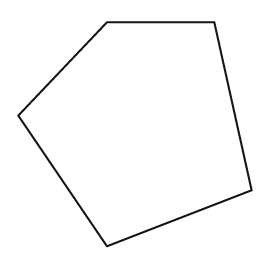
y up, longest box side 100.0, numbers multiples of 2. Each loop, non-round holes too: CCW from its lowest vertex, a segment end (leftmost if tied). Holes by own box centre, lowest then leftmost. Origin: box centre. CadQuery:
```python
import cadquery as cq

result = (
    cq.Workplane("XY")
    .moveTo(-12.0, -48.0)
    .lineTo(50.0, -24.0)
    .lineTo(34.0, 48.0)
    .lineTo(-12.0, 48.0)
    .lineTo(-50.0, 8.0)
    .close()
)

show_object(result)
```